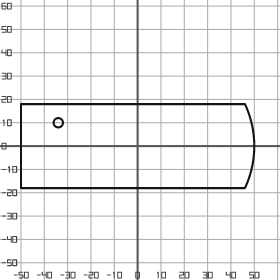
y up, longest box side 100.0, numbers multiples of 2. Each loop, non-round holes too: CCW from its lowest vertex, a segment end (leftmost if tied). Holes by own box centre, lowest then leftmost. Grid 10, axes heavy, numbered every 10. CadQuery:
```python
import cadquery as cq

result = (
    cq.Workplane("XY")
    .moveTo(-50.0, -18.0)
    .lineTo(46.0, -18.0)
    .threePointArc((50.0, 0.0), (46.0, 18.0))
    .lineTo(-50.0, 18.0)
    .close()
    .moveTo(-34.0, 10.0)
    .circle(2.0)
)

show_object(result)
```